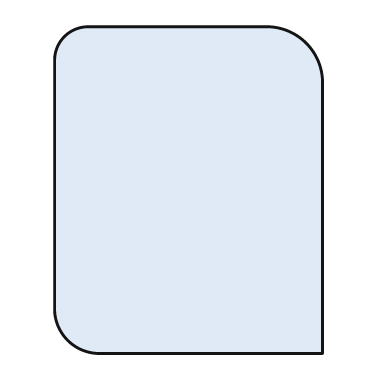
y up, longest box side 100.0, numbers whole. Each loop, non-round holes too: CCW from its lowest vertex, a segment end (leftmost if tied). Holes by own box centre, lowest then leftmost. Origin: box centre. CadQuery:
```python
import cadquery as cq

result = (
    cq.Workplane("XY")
    .moveTo(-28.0, -50.0)
    .lineTo(41.0, -50.0)
    .lineTo(41.0, 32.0)
    .threePointArc((36.0, 45.0), (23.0, 50.0))
    .lineTo(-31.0, 50.0)
    .threePointArc((-38.0, 47.0), (-41.0, 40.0))
    .lineTo(-41.0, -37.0)
    .threePointArc((-37.0, -46.0), (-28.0, -50.0))
    .close()
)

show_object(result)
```